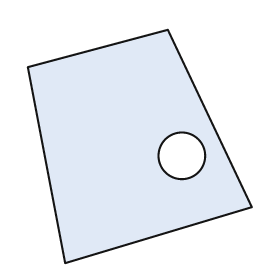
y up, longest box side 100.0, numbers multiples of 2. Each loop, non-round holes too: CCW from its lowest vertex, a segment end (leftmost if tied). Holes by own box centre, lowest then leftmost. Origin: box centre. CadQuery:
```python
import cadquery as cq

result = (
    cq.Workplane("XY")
    .moveTo(-32.0, -50.0)
    .lineTo(48.0, -26.0)
    .lineTo(12.0, 50.0)
    .lineTo(-48.0, 34.0)
    .close()
    .moveTo(18.0, -4.0)
    .circle(10.0)
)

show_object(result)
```